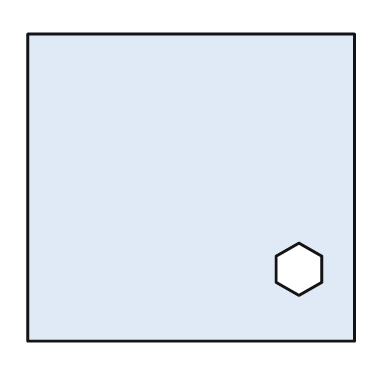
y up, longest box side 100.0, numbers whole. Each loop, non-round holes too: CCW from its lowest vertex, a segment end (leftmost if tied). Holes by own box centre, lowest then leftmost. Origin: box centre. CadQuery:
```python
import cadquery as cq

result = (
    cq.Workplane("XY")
    .moveTo(-50.0, -47.0)
    .lineTo(50.0, -47.0)
    .lineTo(50.0, 47.0)
    .lineTo(-50.0, 47.0)
    .close()
    .moveTo(33.0, -33.0)
    .lineTo(40.0, -29.0)
    .lineTo(40.0, -21.0)
    .lineTo(33.0, -17.0)
    .lineTo(26.0, -21.0)
    .lineTo(26.0, -29.0)
    .close()
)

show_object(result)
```